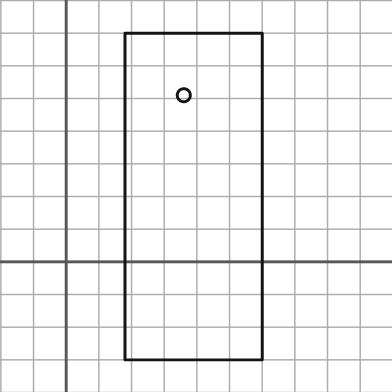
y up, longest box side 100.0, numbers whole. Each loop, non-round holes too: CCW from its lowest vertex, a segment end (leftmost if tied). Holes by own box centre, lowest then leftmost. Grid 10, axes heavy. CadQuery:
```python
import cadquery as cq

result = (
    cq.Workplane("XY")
    .moveTo(18.0, -30.0)
    .lineTo(60.0, -30.0)
    .lineTo(60.0, 70.0)
    .lineTo(18.0, 70.0)
    .close()
    .moveTo(36.0, 51.0)
    .circle(2.0)
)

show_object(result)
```